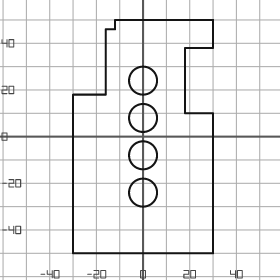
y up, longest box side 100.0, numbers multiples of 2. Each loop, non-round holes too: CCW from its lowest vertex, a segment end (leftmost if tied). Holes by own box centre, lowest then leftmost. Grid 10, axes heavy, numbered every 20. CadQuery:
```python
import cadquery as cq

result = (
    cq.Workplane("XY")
    .moveTo(-30.0, -50.0)
    .lineTo(30.0, -50.0)
    .lineTo(30.0, 10.0)
    .lineTo(18.0, 10.0)
    .lineTo(18.0, 38.0)
    .lineTo(30.0, 38.0)
    .lineTo(30.0, 50.0)
    .lineTo(-12.0, 50.0)
    .lineTo(-12.0, 46.0)
    .lineTo(-16.0, 46.0)
    .lineTo(-16.0, 18.0)
    .lineTo(-30.0, 18.0)
    .close()
    .moveTo(0.0, -24.0)
    .circle(6.0)
    .moveTo(0.0, -8.0)
    .circle(6.0)
    .moveTo(0.0, 8.0)
    .circle(6.0)
    .moveTo(0.0, 24.0)
    .circle(6.0)
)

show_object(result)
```